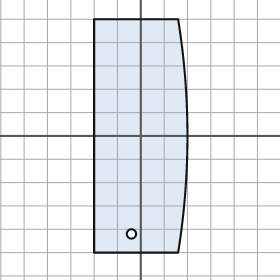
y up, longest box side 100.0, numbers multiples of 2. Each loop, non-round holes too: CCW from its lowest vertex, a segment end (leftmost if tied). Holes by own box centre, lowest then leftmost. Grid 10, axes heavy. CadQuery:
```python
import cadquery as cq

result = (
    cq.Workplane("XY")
    .moveTo(-20.0, -50.0)
    .lineTo(16.0, -50.0)
    .threePointArc((20.0, 0.0), (16.0, 50.0))
    .lineTo(-20.0, 50.0)
    .close()
    .moveTo(-4.0, -42.0)
    .circle(2.0)
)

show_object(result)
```